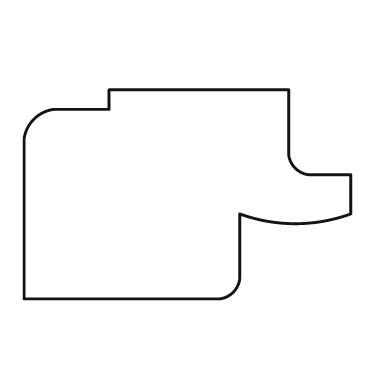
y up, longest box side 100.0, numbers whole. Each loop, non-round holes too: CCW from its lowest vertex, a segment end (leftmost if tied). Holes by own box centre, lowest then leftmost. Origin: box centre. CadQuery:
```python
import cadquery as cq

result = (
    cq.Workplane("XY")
    .moveTo(-50.0, -32.0)
    .lineTo(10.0, -32.0)
    .threePointArc((14.0, -30.0), (16.0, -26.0))
    .lineTo(16.0, -6.0)
    .threePointArc((33.0, -9.0), (50.0, -6.0))
    .lineTo(50.0, 6.0)
    .lineTo(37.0, 6.0)
    .threePointArc((33.0, 8.0), (31.0, 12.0))
    .lineTo(31.0, 32.0)
    .lineTo(-24.0, 32.0)
    .lineTo(-24.0, 26.0)
    .lineTo(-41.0, 26.0)
    .threePointArc((-47.0, 23.0), (-50.0, 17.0))
    .close()
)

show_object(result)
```